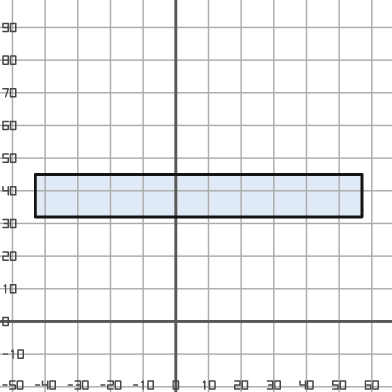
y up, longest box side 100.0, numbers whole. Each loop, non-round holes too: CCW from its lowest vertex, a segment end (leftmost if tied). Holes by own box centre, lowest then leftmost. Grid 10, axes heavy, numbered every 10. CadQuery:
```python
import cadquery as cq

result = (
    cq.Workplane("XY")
    .moveTo(-43.0, 32.0)
    .lineTo(57.0, 32.0)
    .lineTo(57.0, 45.0)
    .lineTo(-43.0, 45.0)
    .close()
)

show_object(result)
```